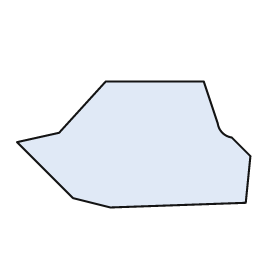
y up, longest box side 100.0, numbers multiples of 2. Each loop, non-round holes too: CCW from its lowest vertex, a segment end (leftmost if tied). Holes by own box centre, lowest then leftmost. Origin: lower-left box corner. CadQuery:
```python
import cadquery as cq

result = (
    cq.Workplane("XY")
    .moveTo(40.0, 0.0)
    .lineTo(98.0, 2.0)
    .lineTo(100.0, 22.0)
    .lineTo(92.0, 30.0)
    .threePointArc((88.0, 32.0), (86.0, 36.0))
    .lineTo(80.0, 54.0)
    .lineTo(38.0, 54.0)
    .lineTo(18.0, 32.0)
    .lineTo(0.0, 28.0)
    .lineTo(24.0, 4.0)
    .close()
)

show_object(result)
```